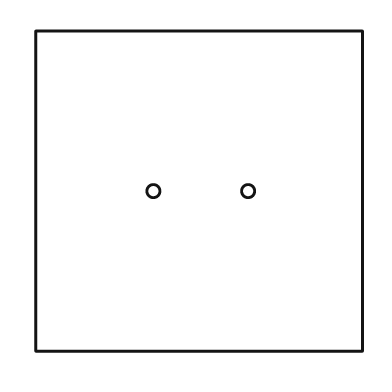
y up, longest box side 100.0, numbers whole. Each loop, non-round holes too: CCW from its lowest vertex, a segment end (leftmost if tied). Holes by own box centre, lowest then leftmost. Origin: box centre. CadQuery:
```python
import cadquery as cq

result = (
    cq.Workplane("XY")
    .moveTo(-50.0, -49.0)
    .lineTo(50.0, -49.0)
    .lineTo(50.0, 49.0)
    .lineTo(-50.0, 49.0)
    .close()
    .moveTo(-14.0, 0.0)
    .circle(2.0)
    .moveTo(15.0, 0.0)
    .circle(2.0)
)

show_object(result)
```